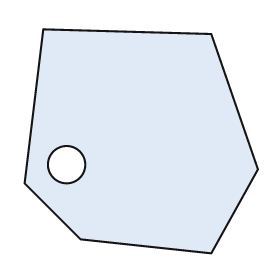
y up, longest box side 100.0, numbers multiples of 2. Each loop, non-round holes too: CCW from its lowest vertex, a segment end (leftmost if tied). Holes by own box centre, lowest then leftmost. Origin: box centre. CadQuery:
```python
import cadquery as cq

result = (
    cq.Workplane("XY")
    .moveTo(30.0, -48.0)
    .lineTo(50.0, -12.0)
    .lineTo(30.0, 46.0)
    .lineTo(-42.0, 48.0)
    .lineTo(-50.0, -18.0)
    .lineTo(-26.0, -42.0)
    .close()
    .moveTo(-32.0, -10.0)
    .circle(8.0)
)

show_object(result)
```